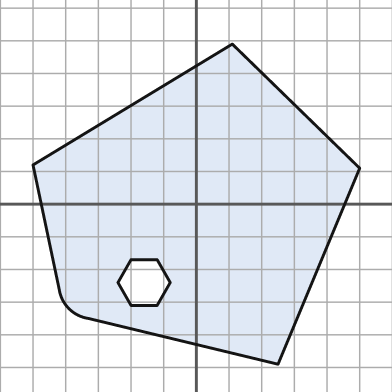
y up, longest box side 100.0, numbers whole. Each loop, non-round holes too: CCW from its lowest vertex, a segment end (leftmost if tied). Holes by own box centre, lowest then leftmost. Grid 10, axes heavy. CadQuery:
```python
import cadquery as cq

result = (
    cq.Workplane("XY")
    .moveTo(25.0, -49.0)
    .lineTo(50.0, 11.0)
    .lineTo(11.0, 49.0)
    .lineTo(-50.0, 12.0)
    .lineTo(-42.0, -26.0)
    .threePointArc((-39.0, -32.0), (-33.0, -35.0))
    .close()
    .moveTo(-20.0, -31.0)
    .lineTo(-12.0, -31.0)
    .lineTo(-8.0, -24.0)
    .lineTo(-12.0, -17.0)
    .lineTo(-20.0, -17.0)
    .lineTo(-24.0, -24.0)
    .close()
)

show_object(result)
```